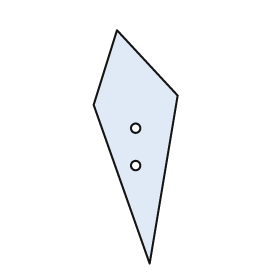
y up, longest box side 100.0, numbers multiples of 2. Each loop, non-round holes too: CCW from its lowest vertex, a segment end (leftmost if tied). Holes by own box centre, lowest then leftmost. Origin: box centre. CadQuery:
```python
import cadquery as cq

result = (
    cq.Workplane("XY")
    .moveTo(6.0, -50.0)
    .lineTo(18.0, 22.0)
    .lineTo(-8.0, 50.0)
    .lineTo(-18.0, 18.0)
    .close()
    .moveTo(0.0, -8.0)
    .circle(2.0)
    .moveTo(0.0, 8.0)
    .circle(2.0)
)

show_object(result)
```